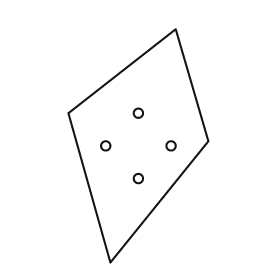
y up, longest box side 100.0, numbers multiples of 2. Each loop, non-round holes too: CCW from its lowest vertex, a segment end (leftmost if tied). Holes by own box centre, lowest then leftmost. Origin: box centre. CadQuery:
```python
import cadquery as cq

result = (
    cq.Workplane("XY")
    .moveTo(-12.0, -50.0)
    .lineTo(30.0, 2.0)
    .lineTo(16.0, 50.0)
    .lineTo(-30.0, 14.0)
    .close()
    .moveTo(0.0, -14.0)
    .circle(2.0)
    .moveTo(-14.0, 0.0)
    .circle(2.0)
    .moveTo(14.0, 0.0)
    .circle(2.0)
    .moveTo(0.0, 14.0)
    .circle(2.0)
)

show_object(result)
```